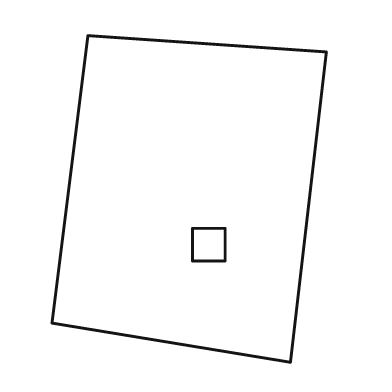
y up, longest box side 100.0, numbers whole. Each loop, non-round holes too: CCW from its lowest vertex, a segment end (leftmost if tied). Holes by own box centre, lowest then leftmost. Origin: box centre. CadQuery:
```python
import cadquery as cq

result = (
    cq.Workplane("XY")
    .moveTo(31.0, -50.0)
    .lineTo(42.0, 45.0)
    .lineTo(-31.0, 50.0)
    .lineTo(-42.0, -38.0)
    .close()
    .moveTo(1.0, -19.0)
    .lineTo(11.0, -19.0)
    .lineTo(11.0, -9.0)
    .lineTo(1.0, -9.0)
    .close()
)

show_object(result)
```